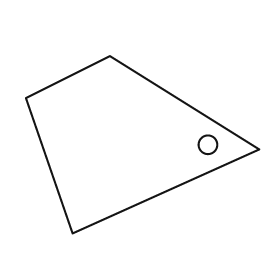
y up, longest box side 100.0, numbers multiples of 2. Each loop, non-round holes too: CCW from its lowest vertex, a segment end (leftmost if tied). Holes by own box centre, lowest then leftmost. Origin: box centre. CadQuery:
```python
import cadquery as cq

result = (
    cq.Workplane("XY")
    .moveTo(-30.0, -38.0)
    .lineTo(50.0, -2.0)
    .lineTo(-14.0, 38.0)
    .lineTo(-50.0, 20.0)
    .close()
    .moveTo(28.0, 0.0)
    .circle(4.0)
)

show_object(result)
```